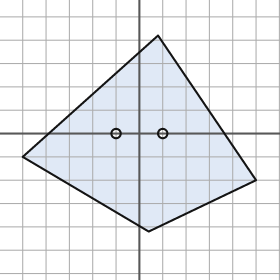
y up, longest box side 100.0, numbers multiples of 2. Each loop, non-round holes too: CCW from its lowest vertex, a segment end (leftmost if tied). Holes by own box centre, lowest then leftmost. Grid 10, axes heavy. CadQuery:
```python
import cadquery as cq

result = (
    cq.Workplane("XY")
    .moveTo(4.0, -42.0)
    .lineTo(50.0, -20.0)
    .lineTo(8.0, 42.0)
    .lineTo(-50.0, -10.0)
    .close()
    .moveTo(-10.0, 0.0)
    .circle(2.0)
    .moveTo(10.0, 0.0)
    .circle(2.0)
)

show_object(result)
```